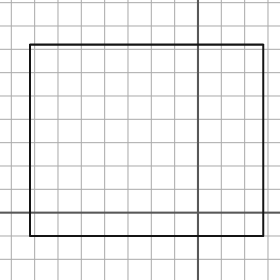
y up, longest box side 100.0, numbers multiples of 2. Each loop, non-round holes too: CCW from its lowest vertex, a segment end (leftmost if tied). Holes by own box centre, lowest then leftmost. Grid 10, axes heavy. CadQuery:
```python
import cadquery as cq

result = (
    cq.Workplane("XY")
    .moveTo(-72.0, -10.0)
    .lineTo(28.0, -10.0)
    .lineTo(28.0, 72.0)
    .lineTo(-72.0, 72.0)
    .close()
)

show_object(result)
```